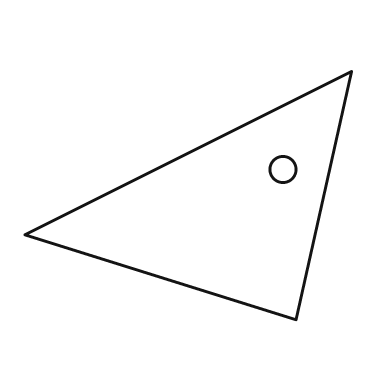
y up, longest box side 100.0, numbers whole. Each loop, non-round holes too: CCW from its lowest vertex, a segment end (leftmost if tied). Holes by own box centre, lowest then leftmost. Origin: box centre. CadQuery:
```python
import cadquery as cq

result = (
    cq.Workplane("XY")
    .moveTo(33.0, -38.0)
    .lineTo(50.0, 38.0)
    .lineTo(-50.0, -12.0)
    .close()
    .moveTo(29.0, 8.0)
    .circle(4.0)
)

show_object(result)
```